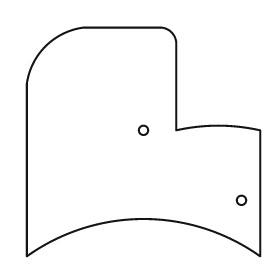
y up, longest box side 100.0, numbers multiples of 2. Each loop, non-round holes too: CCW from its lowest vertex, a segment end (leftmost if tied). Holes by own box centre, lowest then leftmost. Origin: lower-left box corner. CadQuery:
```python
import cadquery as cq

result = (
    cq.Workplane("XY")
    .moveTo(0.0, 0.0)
    .threePointArc((50.0, 16.0), (100.0, 0.0))
    .lineTo(100.0, 54.0)
    .threePointArc((82.0, 56.0), (64.0, 54.0))
    .lineTo(64.0, 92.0)
    .threePointArc((62.0, 96.0), (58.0, 98.0))
    .lineTo(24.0, 98.0)
    .threePointArc((8.0, 90.0), (0.0, 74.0))
    .close()
    .moveTo(92.0, 24.0)
    .circle(2.0)
    .moveTo(50.0, 54.0)
    .circle(2.0)
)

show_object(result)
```